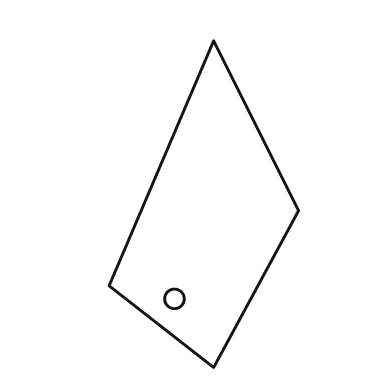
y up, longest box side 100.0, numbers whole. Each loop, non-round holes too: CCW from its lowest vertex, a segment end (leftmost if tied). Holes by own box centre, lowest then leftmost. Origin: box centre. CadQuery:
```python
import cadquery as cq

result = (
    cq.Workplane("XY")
    .moveTo(3.0, -50.0)
    .lineTo(29.0, -2.0)
    .lineTo(3.0, 50.0)
    .lineTo(-29.0, -25.0)
    .close()
    .moveTo(-9.0, -29.0)
    .circle(3.0)
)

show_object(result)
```